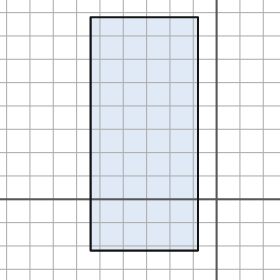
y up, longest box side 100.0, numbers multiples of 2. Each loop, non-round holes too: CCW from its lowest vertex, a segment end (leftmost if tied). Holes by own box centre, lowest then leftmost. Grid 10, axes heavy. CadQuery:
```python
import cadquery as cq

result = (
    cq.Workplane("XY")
    .moveTo(-54.0, -22.0)
    .lineTo(-8.0, -22.0)
    .lineTo(-8.0, 78.0)
    .lineTo(-54.0, 78.0)
    .close()
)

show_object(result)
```